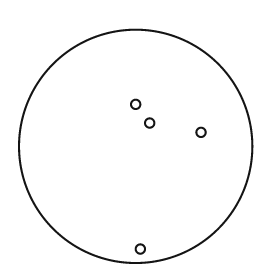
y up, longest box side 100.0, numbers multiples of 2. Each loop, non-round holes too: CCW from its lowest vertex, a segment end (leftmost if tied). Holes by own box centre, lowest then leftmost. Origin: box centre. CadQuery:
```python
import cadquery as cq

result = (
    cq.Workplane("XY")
    .moveTo(0.0, 0.0)
    .circle(50.0)
    .moveTo(2.0, -44.0)
    .circle(2.0)
    .moveTo(28.0, 6.0)
    .circle(2.0)
    .moveTo(6.0, 10.0)
    .circle(2.0)
    .moveTo(0.0, 18.0)
    .circle(2.0)
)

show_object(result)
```